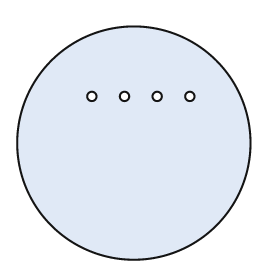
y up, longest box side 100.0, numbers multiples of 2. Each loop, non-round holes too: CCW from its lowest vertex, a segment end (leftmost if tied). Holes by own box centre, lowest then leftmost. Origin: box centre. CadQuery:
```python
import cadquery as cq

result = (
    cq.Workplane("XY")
    .moveTo(0.0, 0.0)
    .circle(50.0)
    .moveTo(-18.0, 20.0)
    .circle(2.0)
    .moveTo(-4.0, 20.0)
    .circle(2.0)
    .moveTo(10.0, 20.0)
    .circle(2.0)
    .moveTo(24.0, 20.0)
    .circle(2.0)
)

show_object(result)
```